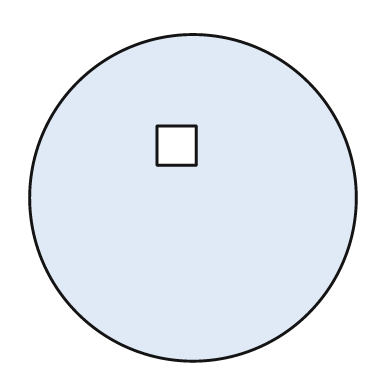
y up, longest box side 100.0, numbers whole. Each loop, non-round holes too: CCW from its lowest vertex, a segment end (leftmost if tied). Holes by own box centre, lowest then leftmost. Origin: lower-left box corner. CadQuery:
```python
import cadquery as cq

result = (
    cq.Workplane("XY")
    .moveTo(50.0, 50.0)
    .circle(50.0)
    .moveTo(39.0, 60.0)
    .lineTo(51.0, 60.0)
    .lineTo(51.0, 72.0)
    .lineTo(39.0, 72.0)
    .close()
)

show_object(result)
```